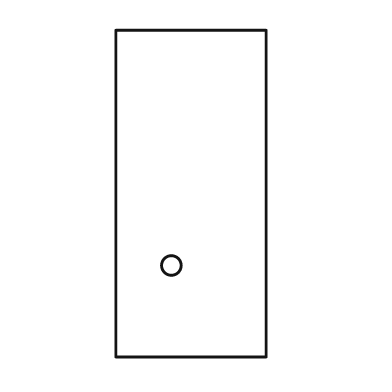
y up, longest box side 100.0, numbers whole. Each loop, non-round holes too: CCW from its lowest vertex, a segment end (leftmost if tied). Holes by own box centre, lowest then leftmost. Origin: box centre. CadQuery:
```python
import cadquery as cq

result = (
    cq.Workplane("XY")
    .moveTo(-23.0, -50.0)
    .lineTo(23.0, -50.0)
    .lineTo(23.0, 50.0)
    .lineTo(-23.0, 50.0)
    .close()
    .moveTo(-6.0, -22.0)
    .circle(3.0)
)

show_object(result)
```